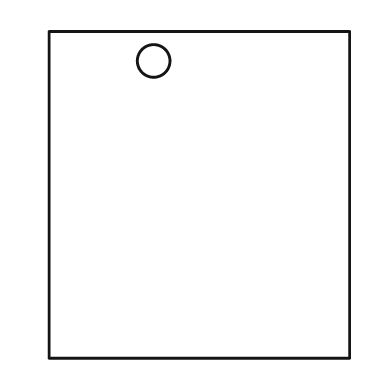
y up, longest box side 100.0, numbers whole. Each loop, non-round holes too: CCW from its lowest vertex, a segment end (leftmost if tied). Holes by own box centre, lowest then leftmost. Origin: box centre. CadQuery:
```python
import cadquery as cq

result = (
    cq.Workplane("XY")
    .moveTo(-46.0, -50.0)
    .lineTo(46.0, -50.0)
    .lineTo(46.0, 50.0)
    .lineTo(-46.0, 50.0)
    .close()
    .moveTo(-14.0, 41.0)
    .circle(5.0)
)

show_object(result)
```